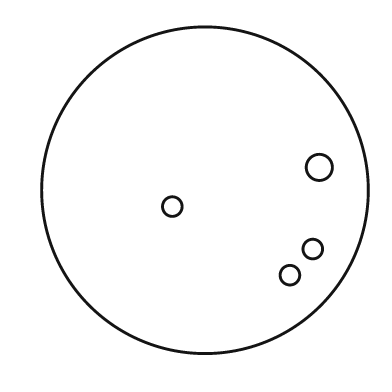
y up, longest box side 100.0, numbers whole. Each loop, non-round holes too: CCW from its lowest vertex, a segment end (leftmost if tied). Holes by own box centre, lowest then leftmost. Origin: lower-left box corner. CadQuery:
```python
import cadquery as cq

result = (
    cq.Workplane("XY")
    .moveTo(50.0, 50.0)
    .circle(50.0)
    .moveTo(76.0, 24.0)
    .circle(3.0)
    .moveTo(83.0, 32.0)
    .circle(3.0)
    .moveTo(40.0, 45.0)
    .circle(3.0)
    .moveTo(85.0, 57.0)
    .circle(4.0)
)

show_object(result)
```